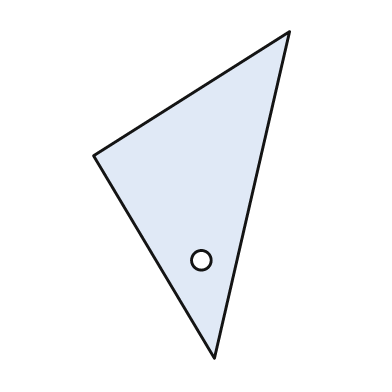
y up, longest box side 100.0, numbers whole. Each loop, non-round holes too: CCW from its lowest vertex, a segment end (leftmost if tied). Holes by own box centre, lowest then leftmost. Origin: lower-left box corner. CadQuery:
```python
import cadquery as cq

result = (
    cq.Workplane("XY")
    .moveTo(37.0, 0.0)
    .lineTo(60.0, 100.0)
    .lineTo(0.0, 62.0)
    .close()
    .moveTo(33.0, 30.0)
    .circle(3.0)
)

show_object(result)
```